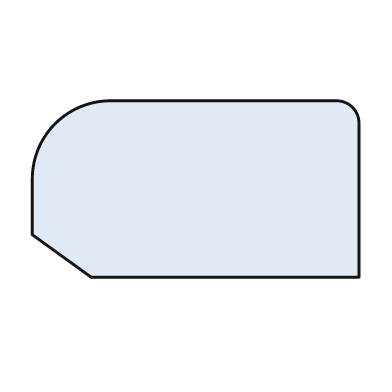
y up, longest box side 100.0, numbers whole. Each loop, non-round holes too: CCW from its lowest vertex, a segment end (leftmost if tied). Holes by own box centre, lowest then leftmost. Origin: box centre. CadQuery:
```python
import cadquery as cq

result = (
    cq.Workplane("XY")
    .moveTo(-32.0, -27.0)
    .lineTo(50.0, -27.0)
    .lineTo(50.0, 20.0)
    .threePointArc((48.0, 25.0), (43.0, 27.0))
    .lineTo(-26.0, 27.0)
    .threePointArc((-43.0, 20.0), (-50.0, 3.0))
    .lineTo(-50.0, -14.0)
    .close()
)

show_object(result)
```